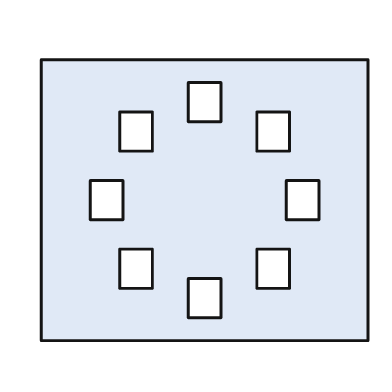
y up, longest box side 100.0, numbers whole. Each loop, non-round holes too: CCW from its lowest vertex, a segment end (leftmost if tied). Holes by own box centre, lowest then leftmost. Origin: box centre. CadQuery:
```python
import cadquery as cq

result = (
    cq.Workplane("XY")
    .moveTo(-50.0, -43.0)
    .lineTo(50.0, -43.0)
    .lineTo(50.0, 43.0)
    .lineTo(-50.0, 43.0)
    .close()
    .moveTo(-5.0, -36.0)
    .lineTo(5.0, -36.0)
    .lineTo(5.0, -24.0)
    .lineTo(-5.0, -24.0)
    .close()
    .moveTo(-26.0, -27.0)
    .lineTo(-16.0, -27.0)
    .lineTo(-16.0, -15.0)
    .lineTo(-26.0, -15.0)
    .close()
    .moveTo(16.0, -27.0)
    .lineTo(26.0, -27.0)
    .lineTo(26.0, -15.0)
    .lineTo(16.0, -15.0)
    .close()
    .moveTo(-35.0, -6.0)
    .lineTo(-25.0, -6.0)
    .lineTo(-25.0, 6.0)
    .lineTo(-35.0, 6.0)
    .close()
    .moveTo(25.0, -6.0)
    .lineTo(35.0, -6.0)
    .lineTo(35.0, 6.0)
    .lineTo(25.0, 6.0)
    .close()
    .moveTo(-26.0, 15.0)
    .lineTo(-16.0, 15.0)
    .lineTo(-16.0, 27.0)
    .lineTo(-26.0, 27.0)
    .close()
    .moveTo(16.0, 15.0)
    .lineTo(26.0, 15.0)
    .lineTo(26.0, 27.0)
    .lineTo(16.0, 27.0)
    .close()
    .moveTo(-5.0, 24.0)
    .lineTo(5.0, 24.0)
    .lineTo(5.0, 36.0)
    .lineTo(-5.0, 36.0)
    .close()
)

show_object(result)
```